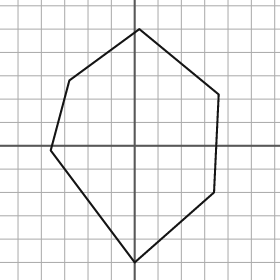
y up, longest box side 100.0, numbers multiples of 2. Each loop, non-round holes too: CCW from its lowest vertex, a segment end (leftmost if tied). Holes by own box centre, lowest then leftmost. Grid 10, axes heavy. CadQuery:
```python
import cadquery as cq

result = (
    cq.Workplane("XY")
    .moveTo(0.0, -50.0)
    .lineTo(34.0, -20.0)
    .lineTo(36.0, 22.0)
    .lineTo(2.0, 50.0)
    .lineTo(-28.0, 28.0)
    .lineTo(-36.0, -2.0)
    .close()
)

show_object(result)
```